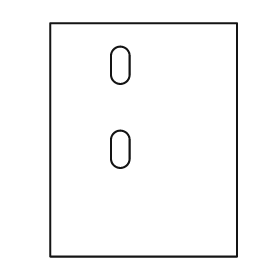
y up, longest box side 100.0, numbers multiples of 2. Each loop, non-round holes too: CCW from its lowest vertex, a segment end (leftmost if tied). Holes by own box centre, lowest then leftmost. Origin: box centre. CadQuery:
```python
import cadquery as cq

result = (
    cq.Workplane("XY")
    .moveTo(-40.0, -50.0)
    .lineTo(40.0, -50.0)
    .lineTo(40.0, 50.0)
    .lineTo(-40.0, 50.0)
    .close()
    .moveTo(-14.0, -8.0)
    .threePointArc((-10.0, -12.0), (-6.0, -8.0))
    .lineTo(-6.0, 0.0)
    .threePointArc((-10.0, 4.0), (-14.0, 0.0))
    .close()
    .moveTo(-14.0, 28.0)
    .threePointArc((-10.0, 24.0), (-6.0, 28.0))
    .lineTo(-6.0, 36.0)
    .threePointArc((-10.0, 40.0), (-14.0, 36.0))
    .close()
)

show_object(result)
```